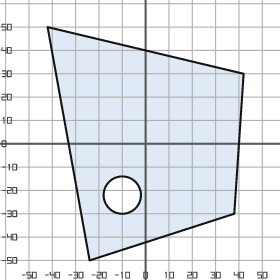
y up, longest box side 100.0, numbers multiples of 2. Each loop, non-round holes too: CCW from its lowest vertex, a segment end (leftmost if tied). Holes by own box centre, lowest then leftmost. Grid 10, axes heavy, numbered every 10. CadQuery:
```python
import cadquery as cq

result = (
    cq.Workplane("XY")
    .moveTo(-24.0, -50.0)
    .lineTo(38.0, -30.0)
    .lineTo(42.0, 30.0)
    .lineTo(-42.0, 50.0)
    .close()
    .moveTo(-10.0, -22.0)
    .circle(8.0)
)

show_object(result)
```